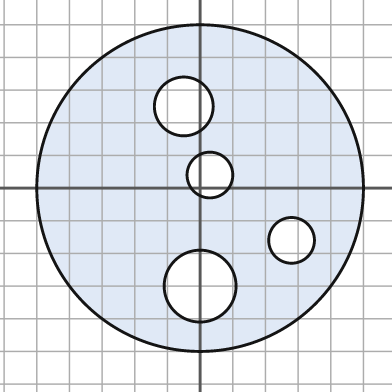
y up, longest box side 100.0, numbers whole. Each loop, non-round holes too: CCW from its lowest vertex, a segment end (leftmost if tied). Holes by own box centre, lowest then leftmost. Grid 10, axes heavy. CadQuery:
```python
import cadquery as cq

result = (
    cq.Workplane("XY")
    .moveTo(0.0, 0.0)
    .circle(50.0)
    .moveTo(0.0, -30.0)
    .circle(11.0)
    .moveTo(28.0, -16.0)
    .circle(7.0)
    .moveTo(3.0, 4.0)
    .circle(7.0)
    .moveTo(-5.0, 25.0)
    .circle(9.0)
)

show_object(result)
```